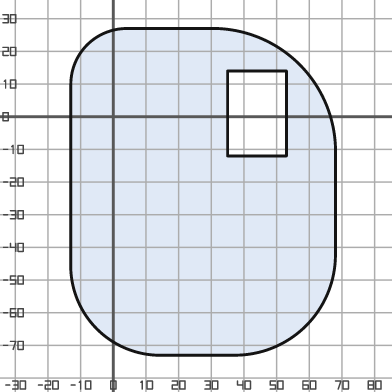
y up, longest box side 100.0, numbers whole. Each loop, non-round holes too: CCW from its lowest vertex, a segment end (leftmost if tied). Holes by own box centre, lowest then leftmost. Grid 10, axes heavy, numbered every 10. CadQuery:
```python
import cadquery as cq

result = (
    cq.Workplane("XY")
    .moveTo(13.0, -73.0)
    .lineTo(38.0, -73.0)
    .threePointArc((59.0, -64.0), (68.0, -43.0))
    .lineTo(68.0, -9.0)
    .threePointArc((57.0, 16.0), (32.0, 27.0))
    .lineTo(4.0, 27.0)
    .threePointArc((-8.0, 22.0), (-13.0, 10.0))
    .lineTo(-13.0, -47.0)
    .threePointArc((-5.0, -65.0), (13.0, -73.0))
    .close()
    .moveTo(35.0, -12.0)
    .lineTo(53.0, -12.0)
    .lineTo(53.0, 14.0)
    .lineTo(35.0, 14.0)
    .close()
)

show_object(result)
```